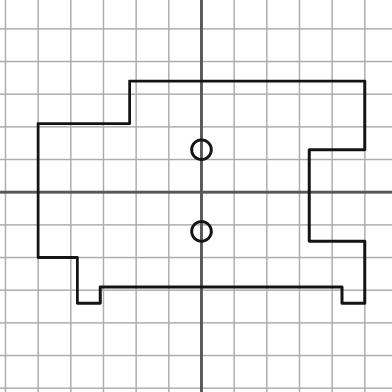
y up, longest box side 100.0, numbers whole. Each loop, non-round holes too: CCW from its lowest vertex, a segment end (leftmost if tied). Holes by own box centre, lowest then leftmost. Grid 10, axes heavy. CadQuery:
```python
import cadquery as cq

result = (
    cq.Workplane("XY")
    .moveTo(-38.0, -34.0)
    .lineTo(-31.0, -34.0)
    .lineTo(-31.0, -29.0)
    .lineTo(43.0, -29.0)
    .lineTo(43.0, -34.0)
    .lineTo(50.0, -34.0)
    .lineTo(50.0, -15.0)
    .lineTo(33.0, -15.0)
    .lineTo(33.0, 13.0)
    .lineTo(50.0, 13.0)
    .lineTo(50.0, 34.0)
    .lineTo(-22.0, 34.0)
    .lineTo(-22.0, 21.0)
    .lineTo(-50.0, 21.0)
    .lineTo(-50.0, -20.0)
    .lineTo(-38.0, -20.0)
    .close()
    .moveTo(0.0, -12.0)
    .circle(3.0)
    .moveTo(0.0, 13.0)
    .circle(3.0)
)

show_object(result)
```